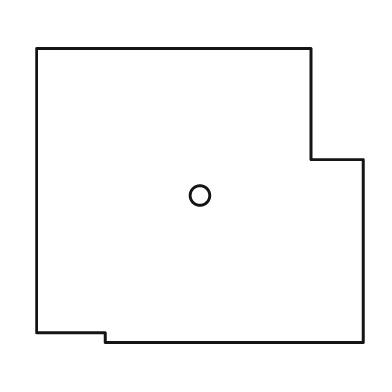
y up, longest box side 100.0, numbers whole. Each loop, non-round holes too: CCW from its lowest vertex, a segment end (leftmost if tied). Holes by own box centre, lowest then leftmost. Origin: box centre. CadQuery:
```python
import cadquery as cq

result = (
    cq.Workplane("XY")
    .moveTo(-29.0, -45.0)
    .lineTo(50.0, -45.0)
    .lineTo(50.0, 11.0)
    .lineTo(34.0, 11.0)
    .lineTo(34.0, 45.0)
    .lineTo(-50.0, 45.0)
    .lineTo(-50.0, -42.0)
    .lineTo(-29.0, -42.0)
    .close()
    .moveTo(0.0, 0.0)
    .circle(3.0)
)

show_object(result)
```